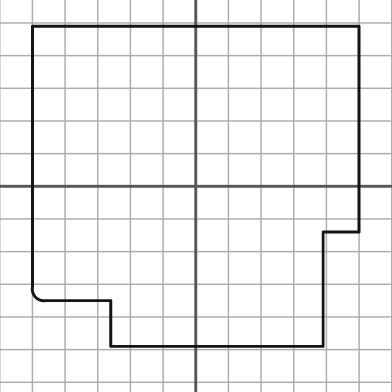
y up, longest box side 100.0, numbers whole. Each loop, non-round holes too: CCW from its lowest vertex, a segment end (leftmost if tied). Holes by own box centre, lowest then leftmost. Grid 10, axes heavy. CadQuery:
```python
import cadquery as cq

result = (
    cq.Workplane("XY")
    .moveTo(-26.0, -49.0)
    .lineTo(39.0, -49.0)
    .lineTo(39.0, -14.0)
    .lineTo(50.0, -14.0)
    .lineTo(50.0, 49.0)
    .lineTo(-50.0, 49.0)
    .lineTo(-50.0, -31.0)
    .threePointArc((-49.0, -34.0), (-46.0, -35.0))
    .lineTo(-26.0, -35.0)
    .close()
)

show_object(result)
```